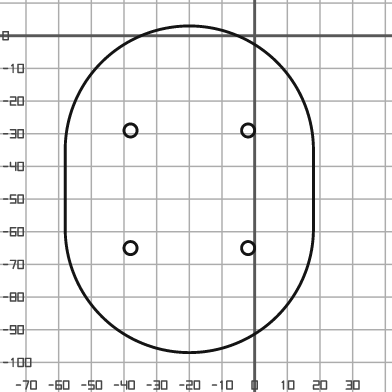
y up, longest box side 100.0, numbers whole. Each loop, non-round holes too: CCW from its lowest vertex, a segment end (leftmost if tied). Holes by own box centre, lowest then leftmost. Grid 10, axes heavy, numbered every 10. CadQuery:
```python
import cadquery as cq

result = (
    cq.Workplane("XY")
    .moveTo(-58.0, -59.0)
    .threePointArc((-20.0, -97.0), (18.0, -59.0))
    .lineTo(18.0, -35.0)
    .threePointArc((-20.0, 3.0), (-58.0, -35.0))
    .close()
    .moveTo(-38.0, -65.0)
    .circle(2.0)
    .moveTo(-2.0, -65.0)
    .circle(2.0)
    .moveTo(-38.0, -29.0)
    .circle(2.0)
    .moveTo(-2.0, -29.0)
    .circle(2.0)
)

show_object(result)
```